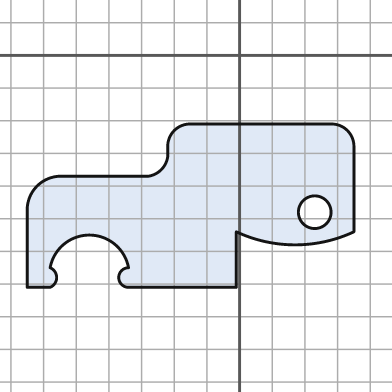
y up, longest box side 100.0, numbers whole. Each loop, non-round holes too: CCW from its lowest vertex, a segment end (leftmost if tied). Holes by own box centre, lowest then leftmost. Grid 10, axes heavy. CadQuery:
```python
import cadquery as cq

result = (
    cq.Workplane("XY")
    .moveTo(-65.0, -71.0)
    .lineTo(-58.0, -71.0)
    .threePointArc((-56.0, -68.0), (-58.0, -65.0))
    .threePointArc((-46.0, -55.0), (-34.0, -65.0))
    .threePointArc((-37.0, -68.0), (-34.0, -71.0))
    .lineTo(-1.0, -71.0)
    .lineTo(-1.0, -54.0)
    .threePointArc((17.0, -58.0), (35.0, -54.0))
    .lineTo(35.0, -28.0)
    .threePointArc((33.0, -23.0), (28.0, -21.0))
    .lineTo(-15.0, -21.0)
    .threePointArc((-20.0, -23.0), (-22.0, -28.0))
    .lineTo(-22.0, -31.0)
    .threePointArc((-24.0, -35.0), (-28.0, -37.0))
    .lineTo(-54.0, -37.0)
    .threePointArc((-62.0, -40.0), (-65.0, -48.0))
    .close()
    .moveTo(23.0, -48.0)
    .circle(5.0)
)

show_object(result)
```